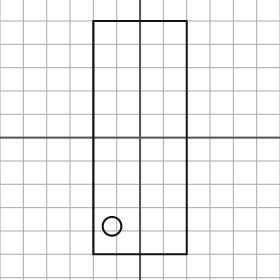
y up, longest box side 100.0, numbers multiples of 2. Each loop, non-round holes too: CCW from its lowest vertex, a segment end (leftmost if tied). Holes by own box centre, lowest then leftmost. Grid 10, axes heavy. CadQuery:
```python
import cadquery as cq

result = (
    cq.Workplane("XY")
    .moveTo(-20.0, -50.0)
    .lineTo(20.0, -50.0)
    .lineTo(20.0, 50.0)
    .lineTo(-20.0, 50.0)
    .close()
    .moveTo(-12.0, -38.0)
    .circle(4.0)
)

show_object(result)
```